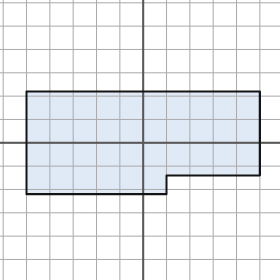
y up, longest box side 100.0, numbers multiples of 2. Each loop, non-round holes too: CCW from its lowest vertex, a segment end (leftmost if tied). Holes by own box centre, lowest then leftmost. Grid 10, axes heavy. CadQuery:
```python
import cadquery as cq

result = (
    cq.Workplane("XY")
    .moveTo(-50.0, -22.0)
    .lineTo(10.0, -22.0)
    .lineTo(10.0, -14.0)
    .lineTo(50.0, -14.0)
    .lineTo(50.0, 22.0)
    .lineTo(-50.0, 22.0)
    .close()
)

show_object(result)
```